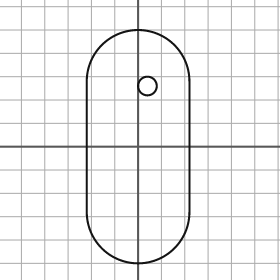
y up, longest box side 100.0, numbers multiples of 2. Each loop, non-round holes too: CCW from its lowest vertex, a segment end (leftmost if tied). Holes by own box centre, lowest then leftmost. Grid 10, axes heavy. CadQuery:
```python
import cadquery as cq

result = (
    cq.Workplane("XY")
    .moveTo(-22.0, -28.0)
    .threePointArc((0.0, -50.0), (22.0, -28.0))
    .lineTo(22.0, 28.0)
    .threePointArc((0.0, 50.0), (-22.0, 28.0))
    .close()
    .moveTo(4.0, 26.0)
    .circle(4.0)
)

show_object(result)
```